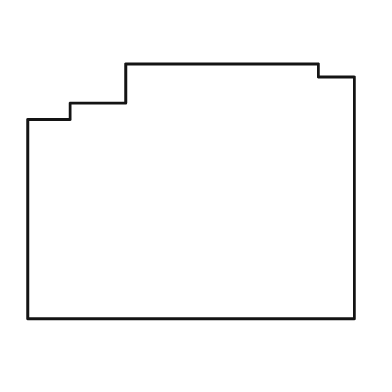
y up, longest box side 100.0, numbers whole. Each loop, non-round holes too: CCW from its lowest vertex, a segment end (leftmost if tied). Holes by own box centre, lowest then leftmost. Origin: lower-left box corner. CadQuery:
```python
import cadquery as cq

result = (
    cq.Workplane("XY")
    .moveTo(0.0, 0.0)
    .lineTo(100.0, 0.0)
    .lineTo(100.0, 74.0)
    .lineTo(89.0, 74.0)
    .lineTo(89.0, 78.0)
    .lineTo(30.0, 78.0)
    .lineTo(30.0, 66.0)
    .lineTo(13.0, 66.0)
    .lineTo(13.0, 61.0)
    .lineTo(0.0, 61.0)
    .close()
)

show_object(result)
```